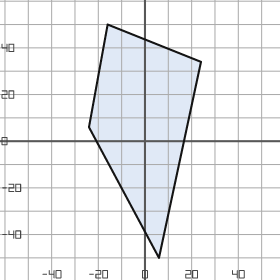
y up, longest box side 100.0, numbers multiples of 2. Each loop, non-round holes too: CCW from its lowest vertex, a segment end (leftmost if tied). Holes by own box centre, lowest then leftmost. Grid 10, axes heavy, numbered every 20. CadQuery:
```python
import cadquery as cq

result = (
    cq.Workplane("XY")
    .moveTo(6.0, -50.0)
    .lineTo(24.0, 34.0)
    .lineTo(-16.0, 50.0)
    .lineTo(-24.0, 6.0)
    .close()
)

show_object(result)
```